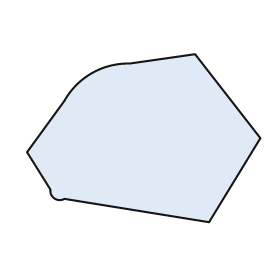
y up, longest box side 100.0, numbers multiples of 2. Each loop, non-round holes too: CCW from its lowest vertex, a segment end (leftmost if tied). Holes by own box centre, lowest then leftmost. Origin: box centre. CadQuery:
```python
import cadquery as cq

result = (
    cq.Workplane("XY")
    .moveTo(28.0, -36.0)
    .lineTo(50.0, 0.0)
    .lineTo(22.0, 36.0)
    .lineTo(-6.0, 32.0)
    .threePointArc((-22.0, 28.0), (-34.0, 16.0))
    .lineTo(-50.0, -6.0)
    .lineTo(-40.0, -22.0)
    .threePointArc((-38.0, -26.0), (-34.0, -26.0))
    .close()
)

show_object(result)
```